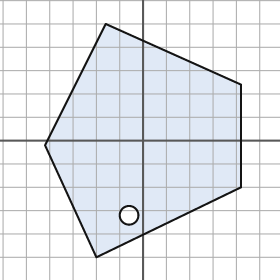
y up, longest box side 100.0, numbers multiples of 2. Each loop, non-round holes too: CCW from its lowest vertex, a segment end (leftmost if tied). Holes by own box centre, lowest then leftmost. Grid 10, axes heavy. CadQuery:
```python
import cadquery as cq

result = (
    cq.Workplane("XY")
    .moveTo(-20.0, -50.0)
    .lineTo(42.0, -20.0)
    .lineTo(42.0, 24.0)
    .lineTo(-16.0, 50.0)
    .lineTo(-42.0, -2.0)
    .close()
    .moveTo(-6.0, -32.0)
    .circle(4.0)
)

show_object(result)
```